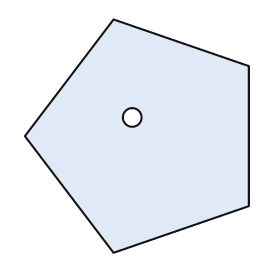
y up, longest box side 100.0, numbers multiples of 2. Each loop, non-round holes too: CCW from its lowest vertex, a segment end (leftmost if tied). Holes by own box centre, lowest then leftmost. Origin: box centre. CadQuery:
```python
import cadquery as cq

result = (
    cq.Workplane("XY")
    .moveTo(-10.0, -50.0)
    .lineTo(48.0, -30.0)
    .lineTo(48.0, 30.0)
    .lineTo(-10.0, 50.0)
    .lineTo(-48.0, 0.0)
    .close()
    .moveTo(-2.0, 8.0)
    .circle(4.0)
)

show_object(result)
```